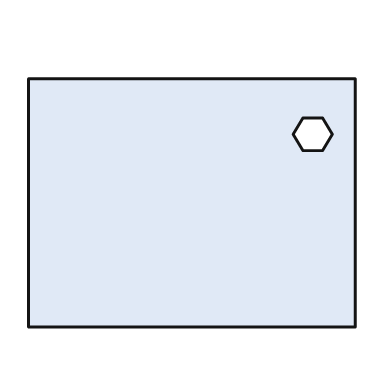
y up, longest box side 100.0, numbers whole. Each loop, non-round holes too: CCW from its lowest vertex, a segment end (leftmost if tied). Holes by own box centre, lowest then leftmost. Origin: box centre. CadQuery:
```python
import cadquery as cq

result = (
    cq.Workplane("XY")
    .moveTo(-50.0, -38.0)
    .lineTo(50.0, -38.0)
    .lineTo(50.0, 38.0)
    .lineTo(-50.0, 38.0)
    .close()
    .moveTo(34.0, 16.0)
    .lineTo(40.0, 16.0)
    .lineTo(43.0, 21.0)
    .lineTo(40.0, 26.0)
    .lineTo(34.0, 26.0)
    .lineTo(31.0, 21.0)
    .close()
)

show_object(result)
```